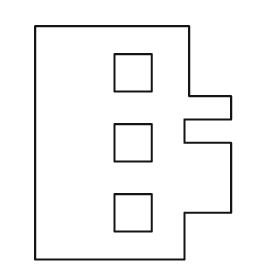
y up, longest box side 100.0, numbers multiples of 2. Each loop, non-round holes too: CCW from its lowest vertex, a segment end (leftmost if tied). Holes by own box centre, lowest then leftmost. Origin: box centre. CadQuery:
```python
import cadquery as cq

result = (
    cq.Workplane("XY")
    .moveTo(-42.0, -50.0)
    .lineTo(22.0, -50.0)
    .lineTo(22.0, -30.0)
    .lineTo(42.0, -30.0)
    .lineTo(42.0, 0.0)
    .lineTo(22.0, 0.0)
    .lineTo(22.0, 10.0)
    .lineTo(42.0, 10.0)
    .lineTo(42.0, 20.0)
    .lineTo(24.0, 20.0)
    .lineTo(24.0, 50.0)
    .lineTo(-42.0, 50.0)
    .close()
    .moveTo(-8.0, -38.0)
    .lineTo(8.0, -38.0)
    .lineTo(8.0, -22.0)
    .lineTo(-8.0, -22.0)
    .close()
    .moveTo(-8.0, -8.0)
    .lineTo(8.0, -8.0)
    .lineTo(8.0, 8.0)
    .lineTo(-8.0, 8.0)
    .close()
    .moveTo(-8.0, 22.0)
    .lineTo(8.0, 22.0)
    .lineTo(8.0, 38.0)
    .lineTo(-8.0, 38.0)
    .close()
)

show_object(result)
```